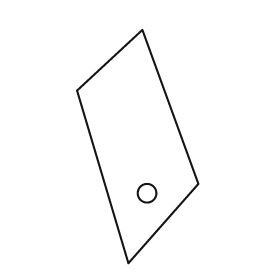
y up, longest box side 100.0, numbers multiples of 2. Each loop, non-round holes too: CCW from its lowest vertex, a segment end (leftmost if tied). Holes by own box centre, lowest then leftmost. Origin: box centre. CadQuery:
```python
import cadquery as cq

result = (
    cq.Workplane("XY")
    .moveTo(-4.0, -50.0)
    .lineTo(26.0, -16.0)
    .lineTo(2.0, 50.0)
    .lineTo(-26.0, 24.0)
    .close()
    .moveTo(4.0, -20.0)
    .circle(4.0)
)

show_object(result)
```